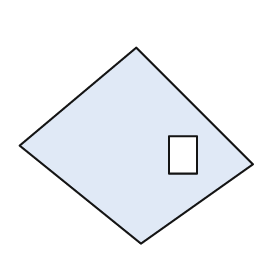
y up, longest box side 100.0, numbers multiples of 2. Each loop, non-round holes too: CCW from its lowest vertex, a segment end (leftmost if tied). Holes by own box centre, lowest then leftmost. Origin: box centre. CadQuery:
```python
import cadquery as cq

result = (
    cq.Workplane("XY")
    .moveTo(2.0, -42.0)
    .lineTo(50.0, -8.0)
    .lineTo(0.0, 42.0)
    .lineTo(-50.0, 0.0)
    .close()
    .moveTo(14.0, -12.0)
    .lineTo(26.0, -12.0)
    .lineTo(26.0, 4.0)
    .lineTo(14.0, 4.0)
    .close()
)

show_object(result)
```